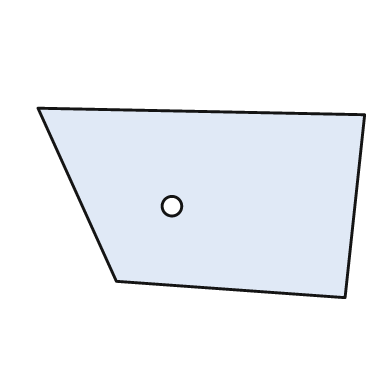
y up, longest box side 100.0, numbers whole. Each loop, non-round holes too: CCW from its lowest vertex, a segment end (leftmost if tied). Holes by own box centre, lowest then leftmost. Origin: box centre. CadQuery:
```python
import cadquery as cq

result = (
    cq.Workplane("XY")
    .moveTo(44.0, -29.0)
    .lineTo(50.0, 27.0)
    .lineTo(-50.0, 29.0)
    .lineTo(-26.0, -24.0)
    .close()
    .moveTo(-9.0, -1.0)
    .circle(3.0)
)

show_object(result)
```